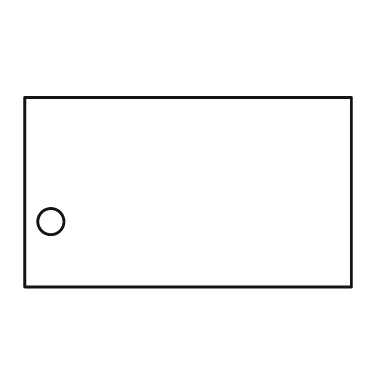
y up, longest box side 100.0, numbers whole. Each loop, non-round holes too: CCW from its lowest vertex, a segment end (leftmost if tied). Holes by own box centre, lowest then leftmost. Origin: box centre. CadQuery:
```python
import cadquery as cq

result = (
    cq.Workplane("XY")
    .moveTo(-50.0, -29.0)
    .lineTo(50.0, -29.0)
    .lineTo(50.0, 29.0)
    .lineTo(-50.0, 29.0)
    .close()
    .moveTo(-42.0, -9.0)
    .circle(4.0)
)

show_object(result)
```